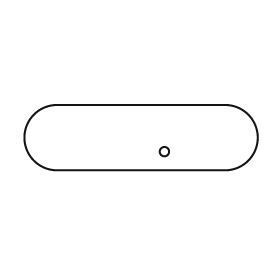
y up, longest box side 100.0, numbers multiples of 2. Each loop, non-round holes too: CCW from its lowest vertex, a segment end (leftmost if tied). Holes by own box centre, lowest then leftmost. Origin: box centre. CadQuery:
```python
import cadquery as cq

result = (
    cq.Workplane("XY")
    .moveTo(-36.0, -14.0)
    .lineTo(36.0, -14.0)
    .threePointArc((50.0, 0.0), (36.0, 14.0))
    .lineTo(-36.0, 14.0)
    .threePointArc((-50.0, 0.0), (-36.0, -14.0))
    .close()
    .moveTo(10.0, -6.0)
    .circle(2.0)
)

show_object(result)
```